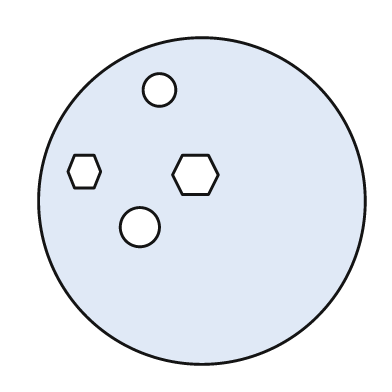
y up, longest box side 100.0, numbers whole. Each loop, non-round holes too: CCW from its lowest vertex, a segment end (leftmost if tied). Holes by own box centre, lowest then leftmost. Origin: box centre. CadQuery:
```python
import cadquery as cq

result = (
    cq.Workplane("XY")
    .moveTo(0.0, 0.0)
    .circle(50.0)
    .moveTo(-19.0, -8.0)
    .circle(6.0)
    .moveTo(-6.0, 2.0)
    .lineTo(2.0, 2.0)
    .lineTo(5.0, 8.0)
    .lineTo(2.0, 14.0)
    .lineTo(-6.0, 14.0)
    .lineTo(-9.0, 8.0)
    .close()
    .moveTo(-39.0, 4.0)
    .lineTo(-33.0, 4.0)
    .lineTo(-31.0, 9.0)
    .lineTo(-33.0, 14.0)
    .lineTo(-39.0, 14.0)
    .lineTo(-41.0, 9.0)
    .close()
    .moveTo(-13.0, 34.0)
    .circle(5.0)
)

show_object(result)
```